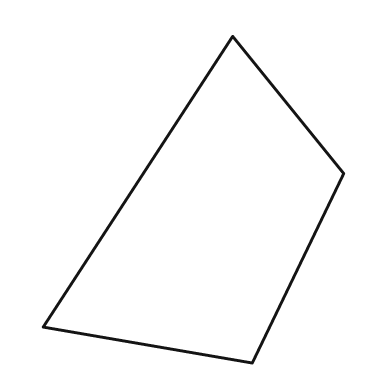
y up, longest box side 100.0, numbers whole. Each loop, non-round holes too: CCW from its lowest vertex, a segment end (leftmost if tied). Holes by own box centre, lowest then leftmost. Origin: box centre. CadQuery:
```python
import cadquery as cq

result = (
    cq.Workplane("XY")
    .moveTo(18.0, -50.0)
    .lineTo(46.0, 8.0)
    .lineTo(12.0, 50.0)
    .lineTo(-46.0, -39.0)
    .close()
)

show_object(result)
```